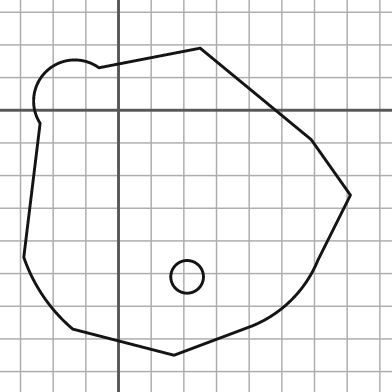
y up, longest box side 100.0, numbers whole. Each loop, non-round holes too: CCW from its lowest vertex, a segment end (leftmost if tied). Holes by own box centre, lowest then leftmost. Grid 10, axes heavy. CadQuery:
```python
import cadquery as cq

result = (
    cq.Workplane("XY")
    .moveTo(17.0, -75.0)
    .lineTo(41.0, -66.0)
    .threePointArc((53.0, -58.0), (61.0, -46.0))
    .lineTo(71.0, -26.0)
    .lineTo(59.0, -9.0)
    .lineTo(25.0, 19.0)
    .lineTo(-6.0, 13.0)
    .threePointArc((-22.0, 12.0), (-24.0, -4.0))
    .lineTo(-29.0, -45.0)
    .threePointArc((-23.0, -57.0), (-14.0, -67.0))
    .close()
    .moveTo(21.0, -51.0)
    .circle(5.0)
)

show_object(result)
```